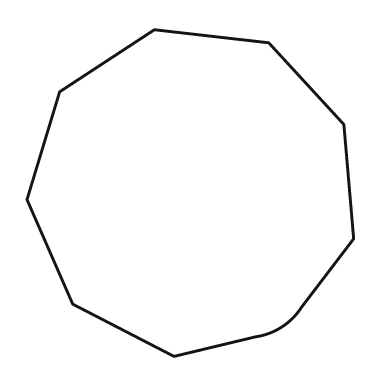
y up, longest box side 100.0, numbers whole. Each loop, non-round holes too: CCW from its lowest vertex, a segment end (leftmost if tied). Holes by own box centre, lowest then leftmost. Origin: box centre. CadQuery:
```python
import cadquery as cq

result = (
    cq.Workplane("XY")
    .moveTo(-5.0, -50.0)
    .lineTo(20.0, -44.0)
    .threePointArc((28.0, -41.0), (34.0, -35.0))
    .lineTo(50.0, -14.0)
    .lineTo(47.0, 21.0)
    .lineTo(24.0, 46.0)
    .lineTo(-11.0, 50.0)
    .lineTo(-40.0, 31.0)
    .lineTo(-50.0, -2.0)
    .lineTo(-36.0, -34.0)
    .close()
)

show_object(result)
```